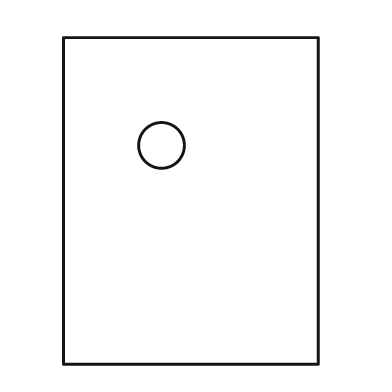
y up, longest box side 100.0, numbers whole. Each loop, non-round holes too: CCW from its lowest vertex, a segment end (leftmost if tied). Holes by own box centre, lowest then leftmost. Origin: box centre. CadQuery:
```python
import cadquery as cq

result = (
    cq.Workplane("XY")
    .moveTo(-39.0, -50.0)
    .lineTo(39.0, -50.0)
    .lineTo(39.0, 50.0)
    .lineTo(-39.0, 50.0)
    .close()
    .moveTo(-9.0, 17.0)
    .circle(7.0)
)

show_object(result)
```